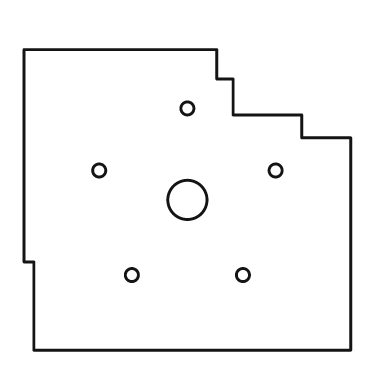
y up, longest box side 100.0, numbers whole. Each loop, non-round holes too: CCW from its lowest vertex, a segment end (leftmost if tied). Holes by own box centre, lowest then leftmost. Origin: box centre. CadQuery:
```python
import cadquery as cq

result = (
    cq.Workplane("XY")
    .moveTo(-47.0, -46.0)
    .lineTo(50.0, -46.0)
    .lineTo(50.0, 19.0)
    .lineTo(35.0, 19.0)
    .lineTo(35.0, 26.0)
    .lineTo(14.0, 26.0)
    .lineTo(14.0, 37.0)
    .lineTo(9.0, 37.0)
    .lineTo(9.0, 46.0)
    .lineTo(-50.0, 46.0)
    .lineTo(-50.0, -19.0)
    .lineTo(-47.0, -19.0)
    .close()
    .moveTo(-17.0, -23.0)
    .circle(2.0)
    .moveTo(17.0, -23.0)
    .circle(2.0)
    .moveTo(0.0, 0.0)
    .circle(6.0)
    .moveTo(-27.0, 9.0)
    .circle(2.0)
    .moveTo(27.0, 9.0)
    .circle(2.0)
    .moveTo(0.0, 28.0)
    .circle(2.0)
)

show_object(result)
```